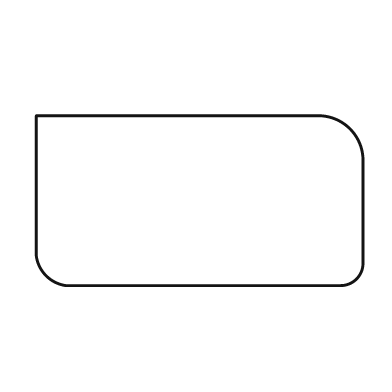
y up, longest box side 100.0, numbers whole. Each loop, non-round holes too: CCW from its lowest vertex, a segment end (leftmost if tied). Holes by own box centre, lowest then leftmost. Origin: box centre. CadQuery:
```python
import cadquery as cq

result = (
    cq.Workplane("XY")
    .moveTo(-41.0, -26.0)
    .lineTo(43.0, -26.0)
    .threePointArc((48.0, -24.0), (50.0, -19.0))
    .lineTo(50.0, 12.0)
    .threePointArc((46.0, 22.0), (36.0, 26.0))
    .lineTo(-50.0, 26.0)
    .lineTo(-50.0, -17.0)
    .threePointArc((-47.0, -23.0), (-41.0, -26.0))
    .close()
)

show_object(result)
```